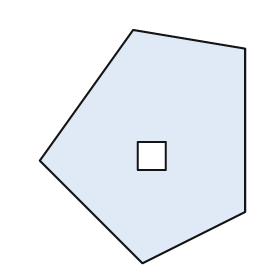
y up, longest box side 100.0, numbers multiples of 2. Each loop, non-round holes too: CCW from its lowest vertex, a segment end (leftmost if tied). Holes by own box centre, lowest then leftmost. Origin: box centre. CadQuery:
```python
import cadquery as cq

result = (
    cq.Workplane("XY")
    .moveTo(0.0, -50.0)
    .lineTo(44.0, -28.0)
    .lineTo(44.0, 42.0)
    .lineTo(-4.0, 50.0)
    .lineTo(-44.0, -6.0)
    .close()
    .moveTo(-2.0, -10.0)
    .lineTo(10.0, -10.0)
    .lineTo(10.0, 2.0)
    .lineTo(-2.0, 2.0)
    .close()
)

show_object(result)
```